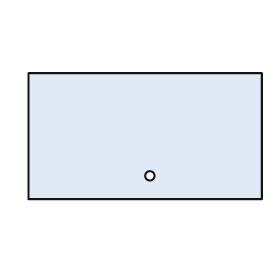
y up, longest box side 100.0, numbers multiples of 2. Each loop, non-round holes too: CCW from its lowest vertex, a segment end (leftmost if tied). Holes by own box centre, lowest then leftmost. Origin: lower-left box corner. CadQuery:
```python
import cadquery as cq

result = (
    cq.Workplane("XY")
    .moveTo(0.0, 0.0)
    .lineTo(100.0, 0.0)
    .lineTo(100.0, 54.0)
    .lineTo(0.0, 54.0)
    .close()
    .moveTo(52.0, 10.0)
    .circle(2.0)
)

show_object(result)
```